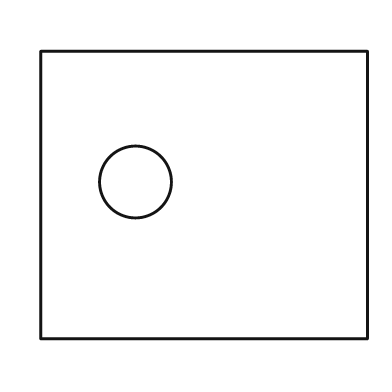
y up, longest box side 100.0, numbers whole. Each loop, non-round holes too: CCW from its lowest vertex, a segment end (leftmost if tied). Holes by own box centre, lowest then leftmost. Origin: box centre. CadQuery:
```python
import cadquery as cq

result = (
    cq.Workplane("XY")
    .moveTo(-50.0, -44.0)
    .lineTo(50.0, -44.0)
    .lineTo(50.0, 44.0)
    .lineTo(-50.0, 44.0)
    .close()
    .moveTo(-21.0, 4.0)
    .circle(11.0)
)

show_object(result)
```